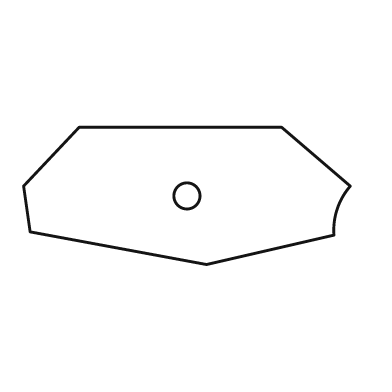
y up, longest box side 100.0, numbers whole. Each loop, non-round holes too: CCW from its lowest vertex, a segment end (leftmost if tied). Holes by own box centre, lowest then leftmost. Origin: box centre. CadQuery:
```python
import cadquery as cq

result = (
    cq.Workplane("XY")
    .moveTo(6.0, -21.0)
    .lineTo(45.0, -12.0)
    .threePointArc((46.0, -4.0), (50.0, 3.0))
    .lineTo(29.0, 21.0)
    .lineTo(-33.0, 21.0)
    .lineTo(-50.0, 3.0)
    .lineTo(-48.0, -11.0)
    .close()
    .moveTo(0.0, 0.0)
    .circle(4.0)
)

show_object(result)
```